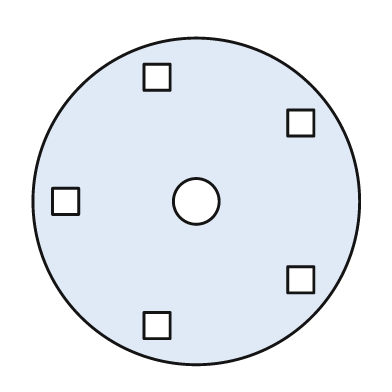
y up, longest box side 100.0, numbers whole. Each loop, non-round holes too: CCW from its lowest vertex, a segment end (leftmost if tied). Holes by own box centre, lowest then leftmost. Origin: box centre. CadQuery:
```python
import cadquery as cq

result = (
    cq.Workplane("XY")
    .moveTo(0.0, 0.0)
    .circle(50.0)
    .moveTo(-16.0, -42.0)
    .lineTo(-8.0, -42.0)
    .lineTo(-8.0, -34.0)
    .lineTo(-16.0, -34.0)
    .close()
    .moveTo(28.0, -28.0)
    .lineTo(36.0, -28.0)
    .lineTo(36.0, -20.0)
    .lineTo(28.0, -20.0)
    .close()
    .moveTo(-44.0, -4.0)
    .lineTo(-36.0, -4.0)
    .lineTo(-36.0, 4.0)
    .lineTo(-44.0, 4.0)
    .close()
    .moveTo(0.0, 0.0)
    .circle(7.0)
    .moveTo(28.0, 20.0)
    .lineTo(36.0, 20.0)
    .lineTo(36.0, 28.0)
    .lineTo(28.0, 28.0)
    .close()
    .moveTo(-16.0, 34.0)
    .lineTo(-8.0, 34.0)
    .lineTo(-8.0, 42.0)
    .lineTo(-16.0, 42.0)
    .close()
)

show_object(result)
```